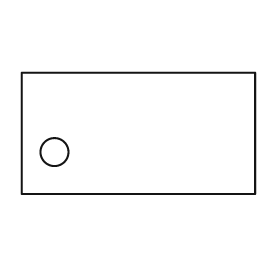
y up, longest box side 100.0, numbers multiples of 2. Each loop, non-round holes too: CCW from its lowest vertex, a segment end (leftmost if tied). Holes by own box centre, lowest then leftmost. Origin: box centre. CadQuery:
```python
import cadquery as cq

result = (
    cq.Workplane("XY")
    .moveTo(-50.0, -26.0)
    .lineTo(50.0, -26.0)
    .lineTo(50.0, 26.0)
    .lineTo(-50.0, 26.0)
    .close()
    .moveTo(-36.0, -8.0)
    .circle(6.0)
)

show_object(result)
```